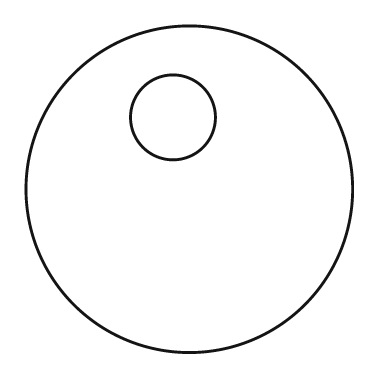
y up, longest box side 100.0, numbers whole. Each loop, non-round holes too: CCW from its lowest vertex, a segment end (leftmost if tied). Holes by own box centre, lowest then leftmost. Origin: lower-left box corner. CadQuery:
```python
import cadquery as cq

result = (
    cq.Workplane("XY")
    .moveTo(50.0, 50.0)
    .circle(50.0)
    .moveTo(45.0, 72.0)
    .circle(13.0)
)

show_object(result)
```